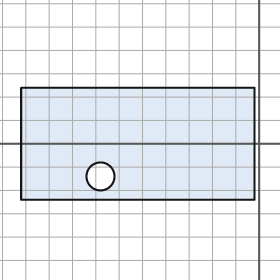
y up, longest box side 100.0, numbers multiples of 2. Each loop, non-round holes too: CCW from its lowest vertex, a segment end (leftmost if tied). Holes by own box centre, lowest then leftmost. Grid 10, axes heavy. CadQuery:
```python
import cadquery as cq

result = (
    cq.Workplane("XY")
    .moveTo(-102.0, -24.0)
    .lineTo(-2.0, -24.0)
    .lineTo(-2.0, 24.0)
    .lineTo(-102.0, 24.0)
    .close()
    .moveTo(-68.0, -14.0)
    .circle(6.0)
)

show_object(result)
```